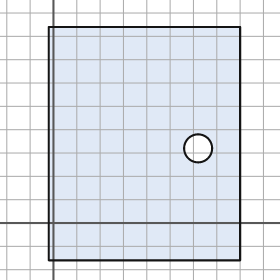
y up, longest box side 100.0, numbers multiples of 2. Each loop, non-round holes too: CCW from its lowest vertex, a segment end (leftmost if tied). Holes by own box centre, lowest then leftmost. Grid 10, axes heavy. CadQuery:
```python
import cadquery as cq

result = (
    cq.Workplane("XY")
    .moveTo(-2.0, -16.0)
    .lineTo(80.0, -16.0)
    .lineTo(80.0, 84.0)
    .lineTo(-2.0, 84.0)
    .close()
    .moveTo(62.0, 32.0)
    .circle(6.0)
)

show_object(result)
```